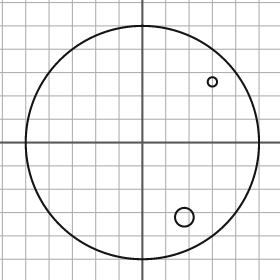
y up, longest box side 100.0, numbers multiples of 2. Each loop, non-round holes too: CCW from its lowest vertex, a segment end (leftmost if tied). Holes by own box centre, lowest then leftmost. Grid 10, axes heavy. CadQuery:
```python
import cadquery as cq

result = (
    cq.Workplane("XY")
    .moveTo(0.0, 0.0)
    .circle(50.0)
    .moveTo(18.0, -32.0)
    .circle(4.0)
    .moveTo(30.0, 26.0)
    .circle(2.0)
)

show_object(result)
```